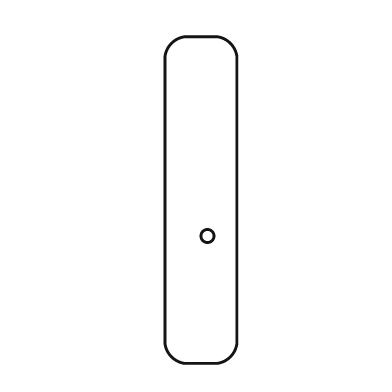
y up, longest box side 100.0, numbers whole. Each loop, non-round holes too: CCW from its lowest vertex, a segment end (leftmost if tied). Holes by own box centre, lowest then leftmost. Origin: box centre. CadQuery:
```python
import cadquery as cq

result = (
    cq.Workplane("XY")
    .moveTo(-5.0, -50.0)
    .lineTo(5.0, -50.0)
    .threePointArc((9.0, -48.0), (11.0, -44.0))
    .lineTo(11.0, 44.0)
    .threePointArc((9.0, 48.0), (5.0, 50.0))
    .lineTo(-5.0, 50.0)
    .threePointArc((-9.0, 48.0), (-11.0, 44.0))
    .lineTo(-11.0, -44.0)
    .threePointArc((-9.0, -48.0), (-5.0, -50.0))
    .close()
    .moveTo(2.0, -11.0)
    .circle(2.0)
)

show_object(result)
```